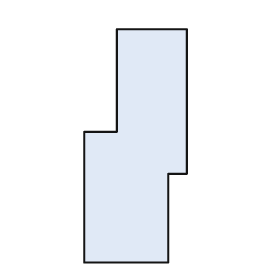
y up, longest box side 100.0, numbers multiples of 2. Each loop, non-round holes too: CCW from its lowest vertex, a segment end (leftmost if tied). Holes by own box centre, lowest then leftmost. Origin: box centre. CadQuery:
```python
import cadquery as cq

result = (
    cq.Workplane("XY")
    .moveTo(-22.0, -50.0)
    .lineTo(14.0, -50.0)
    .lineTo(14.0, -12.0)
    .lineTo(22.0, -12.0)
    .lineTo(22.0, 50.0)
    .lineTo(-8.0, 50.0)
    .lineTo(-8.0, 6.0)
    .lineTo(-22.0, 6.0)
    .close()
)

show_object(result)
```